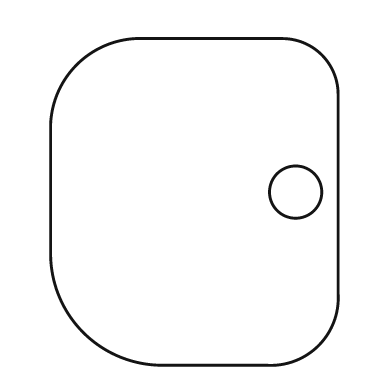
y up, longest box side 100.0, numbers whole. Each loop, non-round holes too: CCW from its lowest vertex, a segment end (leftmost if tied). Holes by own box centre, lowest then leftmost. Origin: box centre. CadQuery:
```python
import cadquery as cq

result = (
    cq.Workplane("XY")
    .moveTo(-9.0, -50.0)
    .lineTo(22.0, -50.0)
    .threePointArc((38.0, -44.0), (44.0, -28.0))
    .lineTo(44.0, 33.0)
    .threePointArc((39.0, 45.0), (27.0, 50.0))
    .lineTo(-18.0, 50.0)
    .threePointArc((-36.0, 42.0), (-44.0, 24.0))
    .lineTo(-44.0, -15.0)
    .threePointArc((-34.0, -40.0), (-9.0, -50.0))
    .close()
    .moveTo(31.0, 3.0)
    .circle(8.0)
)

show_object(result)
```